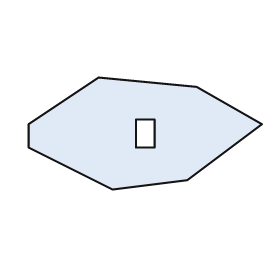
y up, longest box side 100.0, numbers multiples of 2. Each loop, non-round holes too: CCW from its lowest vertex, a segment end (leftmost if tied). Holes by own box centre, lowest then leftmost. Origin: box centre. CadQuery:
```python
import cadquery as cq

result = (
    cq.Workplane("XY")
    .moveTo(-14.0, -24.0)
    .lineTo(18.0, -20.0)
    .lineTo(50.0, 4.0)
    .lineTo(22.0, 20.0)
    .lineTo(-20.0, 24.0)
    .lineTo(-50.0, 4.0)
    .lineTo(-50.0, -6.0)
    .close()
    .moveTo(-4.0, -6.0)
    .lineTo(4.0, -6.0)
    .lineTo(4.0, 6.0)
    .lineTo(-4.0, 6.0)
    .close()
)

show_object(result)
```